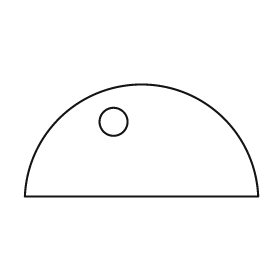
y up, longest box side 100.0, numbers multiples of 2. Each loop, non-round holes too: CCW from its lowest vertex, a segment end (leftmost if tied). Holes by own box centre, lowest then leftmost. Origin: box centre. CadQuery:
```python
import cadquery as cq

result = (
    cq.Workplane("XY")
    .moveTo(-50.0, -24.0)
    .lineTo(50.0, -24.0)
    .threePointArc((0.0, 24.0), (-50.0, -24.0))
    .close()
    .moveTo(-12.0, 8.0)
    .circle(6.0)
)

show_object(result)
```